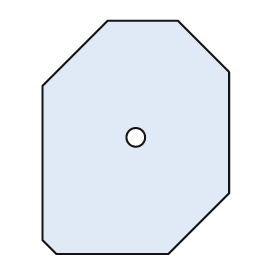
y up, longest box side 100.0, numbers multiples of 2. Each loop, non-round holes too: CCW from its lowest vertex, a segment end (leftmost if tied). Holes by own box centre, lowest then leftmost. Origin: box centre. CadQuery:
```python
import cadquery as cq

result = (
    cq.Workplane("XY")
    .moveTo(-34.0, -50.0)
    .lineTo(14.0, -50.0)
    .lineTo(40.0, -24.0)
    .lineTo(40.0, 28.0)
    .lineTo(18.0, 50.0)
    .lineTo(-12.0, 50.0)
    .lineTo(-40.0, 22.0)
    .lineTo(-40.0, -44.0)
    .close()
    .moveTo(0.0, 0.0)
    .circle(4.0)
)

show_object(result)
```